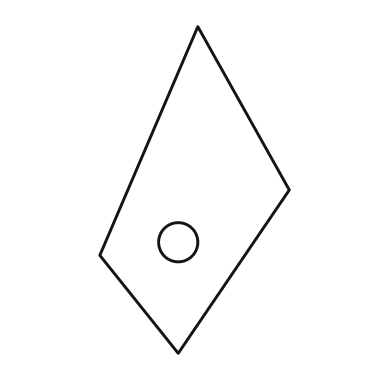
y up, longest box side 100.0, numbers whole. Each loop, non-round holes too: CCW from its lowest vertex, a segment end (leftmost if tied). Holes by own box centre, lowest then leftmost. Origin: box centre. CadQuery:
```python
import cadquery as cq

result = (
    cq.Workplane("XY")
    .moveTo(-5.0, -50.0)
    .lineTo(29.0, 0.0)
    .lineTo(1.0, 50.0)
    .lineTo(-29.0, -20.0)
    .close()
    .moveTo(-5.0, -16.0)
    .circle(6.0)
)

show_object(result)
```